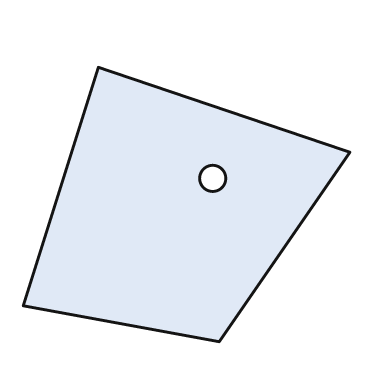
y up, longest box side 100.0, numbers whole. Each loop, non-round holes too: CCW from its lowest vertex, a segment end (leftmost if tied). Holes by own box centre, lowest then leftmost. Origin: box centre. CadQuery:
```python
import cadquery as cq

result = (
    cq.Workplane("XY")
    .moveTo(10.0, -42.0)
    .lineTo(50.0, 16.0)
    .lineTo(-27.0, 42.0)
    .lineTo(-50.0, -31.0)
    .close()
    .moveTo(8.0, 8.0)
    .circle(4.0)
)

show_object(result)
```